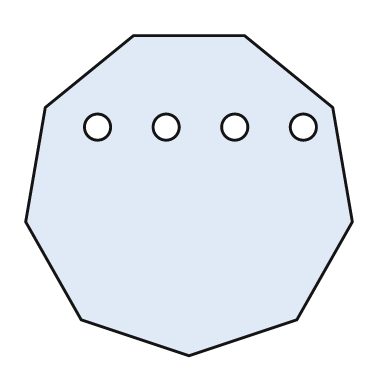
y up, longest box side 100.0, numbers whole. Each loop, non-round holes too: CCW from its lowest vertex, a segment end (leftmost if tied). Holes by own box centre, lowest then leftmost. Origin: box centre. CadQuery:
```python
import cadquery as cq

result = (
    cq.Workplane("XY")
    .moveTo(0.0, -49.0)
    .lineTo(33.0, -38.0)
    .lineTo(50.0, -8.0)
    .lineTo(44.0, 27.0)
    .lineTo(17.0, 49.0)
    .lineTo(-17.0, 49.0)
    .lineTo(-44.0, 27.0)
    .lineTo(-50.0, -8.0)
    .lineTo(-33.0, -38.0)
    .close()
    .moveTo(-28.0, 21.0)
    .circle(4.0)
    .moveTo(-7.0, 21.0)
    .circle(4.0)
    .moveTo(14.0, 21.0)
    .circle(4.0)
    .moveTo(35.0, 21.0)
    .circle(4.0)
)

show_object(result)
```